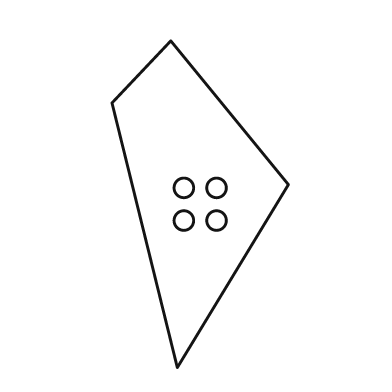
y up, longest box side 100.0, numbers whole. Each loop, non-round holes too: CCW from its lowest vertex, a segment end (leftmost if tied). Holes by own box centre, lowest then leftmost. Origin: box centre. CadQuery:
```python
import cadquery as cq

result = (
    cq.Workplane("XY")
    .moveTo(-7.0, -50.0)
    .lineTo(27.0, 6.0)
    .lineTo(-9.0, 50.0)
    .lineTo(-27.0, 31.0)
    .close()
    .moveTo(-5.0, -5.0)
    .circle(3.0)
    .moveTo(5.0, -5.0)
    .circle(3.0)
    .moveTo(-5.0, 5.0)
    .circle(3.0)
    .moveTo(5.0, 5.0)
    .circle(3.0)
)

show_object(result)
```